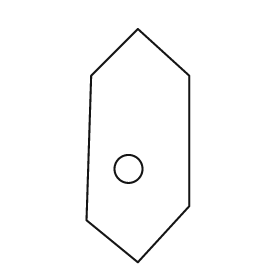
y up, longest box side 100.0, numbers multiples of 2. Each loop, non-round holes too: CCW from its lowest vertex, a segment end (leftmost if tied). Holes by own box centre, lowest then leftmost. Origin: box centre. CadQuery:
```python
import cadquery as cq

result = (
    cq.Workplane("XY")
    .moveTo(0.0, -50.0)
    .lineTo(22.0, -26.0)
    .lineTo(22.0, 30.0)
    .lineTo(0.0, 50.0)
    .lineTo(-20.0, 30.0)
    .lineTo(-22.0, -32.0)
    .close()
    .moveTo(-4.0, -10.0)
    .circle(6.0)
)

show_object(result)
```